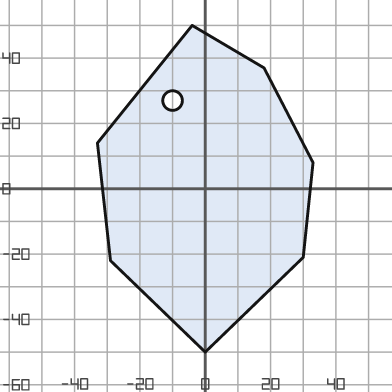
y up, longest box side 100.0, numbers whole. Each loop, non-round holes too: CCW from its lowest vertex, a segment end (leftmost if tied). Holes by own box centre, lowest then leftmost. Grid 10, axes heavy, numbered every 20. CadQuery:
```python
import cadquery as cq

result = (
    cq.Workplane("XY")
    .moveTo(0.0, -50.0)
    .lineTo(30.0, -21.0)
    .lineTo(33.0, 8.0)
    .lineTo(18.0, 37.0)
    .lineTo(-4.0, 50.0)
    .lineTo(-33.0, 14.0)
    .lineTo(-29.0, -22.0)
    .close()
    .moveTo(-10.0, 27.0)
    .circle(3.0)
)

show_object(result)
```